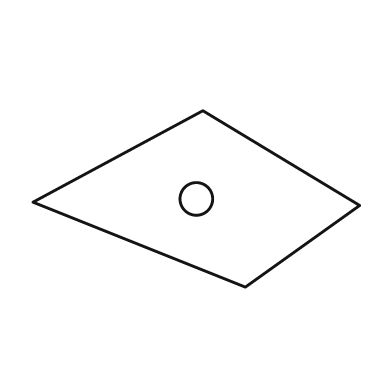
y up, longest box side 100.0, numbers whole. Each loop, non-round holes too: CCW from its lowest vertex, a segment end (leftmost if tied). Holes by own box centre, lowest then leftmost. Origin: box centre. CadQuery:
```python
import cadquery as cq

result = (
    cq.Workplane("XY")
    .moveTo(15.0, -27.0)
    .lineTo(50.0, -2.0)
    .lineTo(2.0, 27.0)
    .lineTo(-50.0, -1.0)
    .close()
    .moveTo(0.0, 0.0)
    .circle(5.0)
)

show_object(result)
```